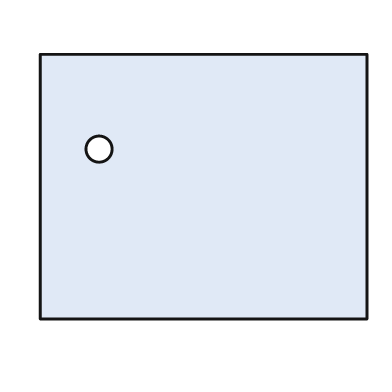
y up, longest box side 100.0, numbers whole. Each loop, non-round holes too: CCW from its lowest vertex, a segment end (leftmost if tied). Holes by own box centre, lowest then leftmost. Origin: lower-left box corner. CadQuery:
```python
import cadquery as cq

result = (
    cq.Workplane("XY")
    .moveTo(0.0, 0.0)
    .lineTo(100.0, 0.0)
    .lineTo(100.0, 81.0)
    .lineTo(0.0, 81.0)
    .close()
    .moveTo(18.0, 52.0)
    .circle(4.0)
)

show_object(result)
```